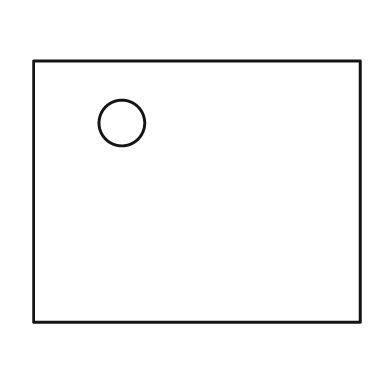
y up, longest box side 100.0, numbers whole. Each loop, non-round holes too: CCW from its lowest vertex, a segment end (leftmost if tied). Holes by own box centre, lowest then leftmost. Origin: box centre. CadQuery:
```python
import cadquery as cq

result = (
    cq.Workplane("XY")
    .moveTo(-50.0, -40.0)
    .lineTo(50.0, -40.0)
    .lineTo(50.0, 40.0)
    .lineTo(-50.0, 40.0)
    .close()
    .moveTo(-23.0, 21.0)
    .circle(7.0)
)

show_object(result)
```